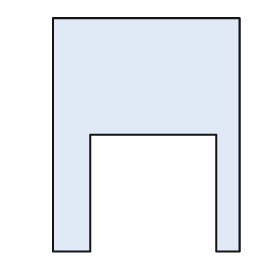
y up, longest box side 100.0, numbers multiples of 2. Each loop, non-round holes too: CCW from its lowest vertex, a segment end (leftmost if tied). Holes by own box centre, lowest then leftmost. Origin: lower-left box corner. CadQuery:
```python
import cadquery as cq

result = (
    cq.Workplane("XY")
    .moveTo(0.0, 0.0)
    .lineTo(16.0, 0.0)
    .lineTo(16.0, 50.0)
    .lineTo(70.0, 50.0)
    .lineTo(70.0, 0.0)
    .lineTo(80.0, 0.0)
    .lineTo(80.0, 100.0)
    .lineTo(0.0, 100.0)
    .close()
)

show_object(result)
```